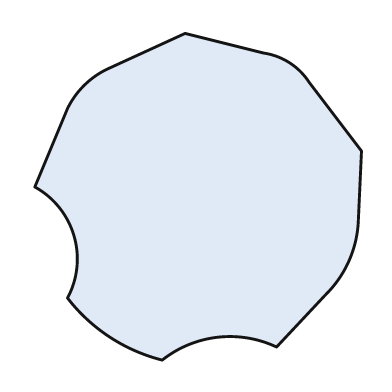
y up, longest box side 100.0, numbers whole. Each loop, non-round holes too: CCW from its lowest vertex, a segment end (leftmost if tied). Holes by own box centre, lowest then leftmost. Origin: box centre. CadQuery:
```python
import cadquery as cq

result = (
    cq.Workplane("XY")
    .moveTo(-11.0, -50.0)
    .threePointArc((6.0, -43.0), (24.0, -46.0))
    .lineTo(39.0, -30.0)
    .threePointArc((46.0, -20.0), (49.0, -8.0))
    .lineTo(50.0, 14.0)
    .lineTo(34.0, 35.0)
    .threePointArc((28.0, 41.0), (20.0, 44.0))
    .lineTo(-4.0, 50.0)
    .lineTo(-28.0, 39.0)
    .threePointArc((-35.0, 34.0), (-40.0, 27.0))
    .lineTo(-50.0, 3.0)
    .threePointArc((-38.0, -12.0), (-40.0, -31.0))
    .threePointArc((-27.0, -43.0), (-11.0, -50.0))
    .close()
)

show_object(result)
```